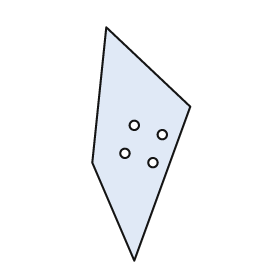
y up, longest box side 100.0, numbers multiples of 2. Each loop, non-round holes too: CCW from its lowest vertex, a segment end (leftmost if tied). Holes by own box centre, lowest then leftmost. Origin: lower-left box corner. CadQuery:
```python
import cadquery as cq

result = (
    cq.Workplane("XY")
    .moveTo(18.0, 0.0)
    .lineTo(42.0, 66.0)
    .lineTo(6.0, 100.0)
    .lineTo(0.0, 42.0)
    .close()
    .moveTo(26.0, 42.0)
    .circle(2.0)
    .moveTo(14.0, 46.0)
    .circle(2.0)
    .moveTo(30.0, 54.0)
    .circle(2.0)
    .moveTo(18.0, 58.0)
    .circle(2.0)
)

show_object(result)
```